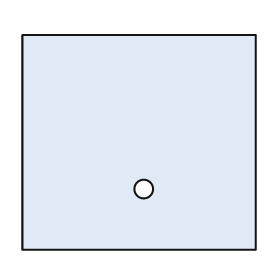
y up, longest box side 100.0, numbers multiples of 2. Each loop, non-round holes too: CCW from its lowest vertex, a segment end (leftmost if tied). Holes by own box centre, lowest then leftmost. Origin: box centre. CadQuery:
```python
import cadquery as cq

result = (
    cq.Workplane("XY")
    .moveTo(-50.0, -46.0)
    .lineTo(50.0, -46.0)
    .lineTo(50.0, 46.0)
    .lineTo(-50.0, 46.0)
    .close()
    .moveTo(2.0, -20.0)
    .circle(4.0)
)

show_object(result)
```